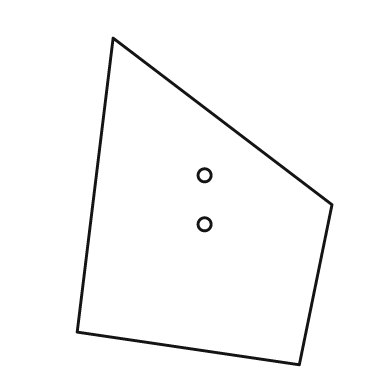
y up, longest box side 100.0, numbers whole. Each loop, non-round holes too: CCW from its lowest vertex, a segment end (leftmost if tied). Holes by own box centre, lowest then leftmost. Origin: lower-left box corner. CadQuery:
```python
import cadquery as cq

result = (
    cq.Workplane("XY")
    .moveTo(68.0, 0.0)
    .lineTo(78.0, 49.0)
    .lineTo(11.0, 100.0)
    .lineTo(0.0, 10.0)
    .close()
    .moveTo(39.0, 43.0)
    .circle(2.0)
    .moveTo(39.0, 58.0)
    .circle(2.0)
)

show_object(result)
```